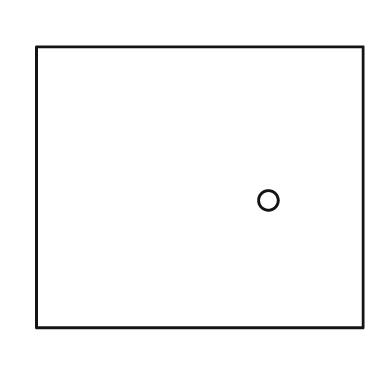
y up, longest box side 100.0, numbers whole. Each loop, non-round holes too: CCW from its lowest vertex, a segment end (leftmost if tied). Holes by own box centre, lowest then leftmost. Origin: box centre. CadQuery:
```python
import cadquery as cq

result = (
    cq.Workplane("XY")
    .moveTo(-50.0, -43.0)
    .lineTo(50.0, -43.0)
    .lineTo(50.0, 43.0)
    .lineTo(-50.0, 43.0)
    .close()
    .moveTo(21.0, -4.0)
    .circle(3.0)
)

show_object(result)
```